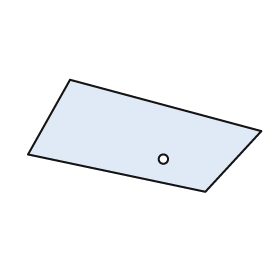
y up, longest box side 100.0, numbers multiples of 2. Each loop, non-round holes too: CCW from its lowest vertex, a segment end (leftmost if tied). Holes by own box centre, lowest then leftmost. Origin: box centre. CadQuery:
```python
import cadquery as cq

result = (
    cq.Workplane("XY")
    .moveTo(26.0, -24.0)
    .lineTo(50.0, 2.0)
    .lineTo(-32.0, 24.0)
    .lineTo(-50.0, -8.0)
    .close()
    .moveTo(8.0, -10.0)
    .circle(2.0)
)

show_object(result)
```